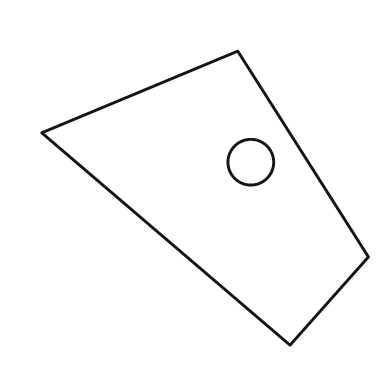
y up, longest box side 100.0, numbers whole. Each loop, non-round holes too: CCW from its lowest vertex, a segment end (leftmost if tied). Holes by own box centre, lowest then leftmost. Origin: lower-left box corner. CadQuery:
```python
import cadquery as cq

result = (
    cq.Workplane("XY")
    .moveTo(76.0, 0.0)
    .lineTo(100.0, 27.0)
    .lineTo(60.0, 90.0)
    .lineTo(0.0, 65.0)
    .close()
    .moveTo(64.0, 56.0)
    .circle(7.0)
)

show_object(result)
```